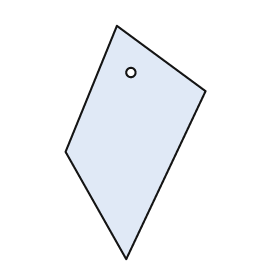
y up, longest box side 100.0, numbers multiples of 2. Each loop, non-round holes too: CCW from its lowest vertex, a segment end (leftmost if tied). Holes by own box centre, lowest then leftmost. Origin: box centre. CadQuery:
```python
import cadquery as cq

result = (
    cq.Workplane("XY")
    .moveTo(-4.0, -50.0)
    .lineTo(30.0, 22.0)
    .lineTo(-8.0, 50.0)
    .lineTo(-30.0, -4.0)
    .close()
    .moveTo(-2.0, 30.0)
    .circle(2.0)
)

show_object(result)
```